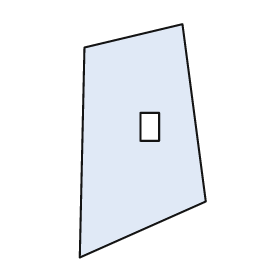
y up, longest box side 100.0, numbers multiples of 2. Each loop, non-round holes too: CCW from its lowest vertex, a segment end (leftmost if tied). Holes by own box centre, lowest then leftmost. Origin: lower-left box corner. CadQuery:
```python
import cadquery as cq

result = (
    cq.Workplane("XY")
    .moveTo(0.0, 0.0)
    .lineTo(54.0, 24.0)
    .lineTo(44.0, 100.0)
    .lineTo(2.0, 90.0)
    .close()
    .moveTo(26.0, 50.0)
    .lineTo(34.0, 50.0)
    .lineTo(34.0, 62.0)
    .lineTo(26.0, 62.0)
    .close()
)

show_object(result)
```